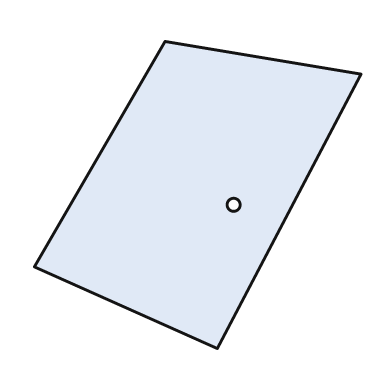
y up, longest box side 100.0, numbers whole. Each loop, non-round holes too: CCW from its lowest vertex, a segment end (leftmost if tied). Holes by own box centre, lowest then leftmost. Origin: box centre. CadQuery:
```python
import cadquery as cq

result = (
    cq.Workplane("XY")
    .moveTo(6.0, -47.0)
    .lineTo(50.0, 37.0)
    .lineTo(-10.0, 47.0)
    .lineTo(-50.0, -22.0)
    .close()
    .moveTo(11.0, -3.0)
    .circle(2.0)
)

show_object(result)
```